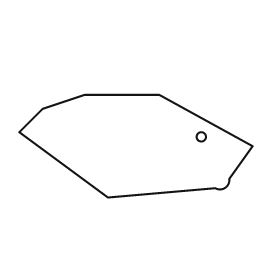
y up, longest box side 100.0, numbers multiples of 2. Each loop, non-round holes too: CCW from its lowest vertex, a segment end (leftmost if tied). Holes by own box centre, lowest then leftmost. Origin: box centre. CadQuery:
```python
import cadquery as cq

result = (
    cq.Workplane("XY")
    .moveTo(-12.0, -22.0)
    .lineTo(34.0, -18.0)
    .threePointArc((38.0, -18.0), (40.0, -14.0))
    .lineTo(50.0, 0.0)
    .lineTo(10.0, 22.0)
    .lineTo(-22.0, 22.0)
    .lineTo(-40.0, 16.0)
    .lineTo(-50.0, 6.0)
    .close()
    .moveTo(28.0, 4.0)
    .circle(2.0)
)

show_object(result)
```